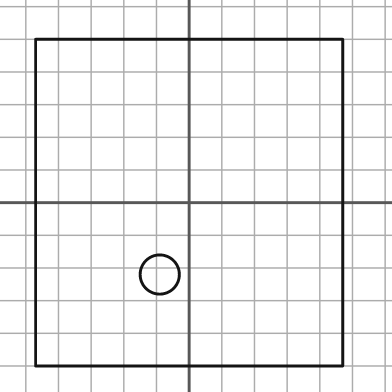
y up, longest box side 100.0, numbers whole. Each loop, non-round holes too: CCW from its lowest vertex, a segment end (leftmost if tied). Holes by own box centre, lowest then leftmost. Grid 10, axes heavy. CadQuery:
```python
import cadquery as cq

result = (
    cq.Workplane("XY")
    .moveTo(-47.0, -50.0)
    .lineTo(47.0, -50.0)
    .lineTo(47.0, 50.0)
    .lineTo(-47.0, 50.0)
    .close()
    .moveTo(-9.0, -22.0)
    .circle(6.0)
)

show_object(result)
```